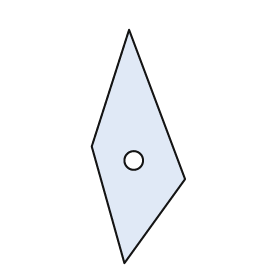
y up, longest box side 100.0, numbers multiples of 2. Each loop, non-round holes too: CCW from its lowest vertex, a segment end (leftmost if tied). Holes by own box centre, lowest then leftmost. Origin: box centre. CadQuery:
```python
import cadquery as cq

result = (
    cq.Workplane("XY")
    .moveTo(-6.0, -50.0)
    .lineTo(20.0, -14.0)
    .lineTo(-4.0, 50.0)
    .lineTo(-20.0, 0.0)
    .close()
    .moveTo(-2.0, -6.0)
    .circle(4.0)
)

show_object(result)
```